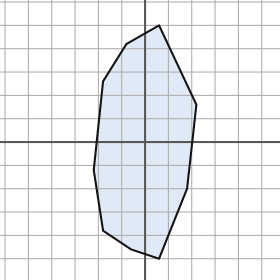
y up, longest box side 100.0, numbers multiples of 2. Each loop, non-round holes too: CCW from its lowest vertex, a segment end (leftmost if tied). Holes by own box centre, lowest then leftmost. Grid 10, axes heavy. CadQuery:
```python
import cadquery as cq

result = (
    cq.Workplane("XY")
    .moveTo(6.0, -50.0)
    .lineTo(18.0, -20.0)
    .lineTo(22.0, 16.0)
    .lineTo(6.0, 50.0)
    .lineTo(-8.0, 42.0)
    .lineTo(-18.0, 26.0)
    .lineTo(-22.0, -12.0)
    .lineTo(-18.0, -38.0)
    .lineTo(-6.0, -46.0)
    .close()
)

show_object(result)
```